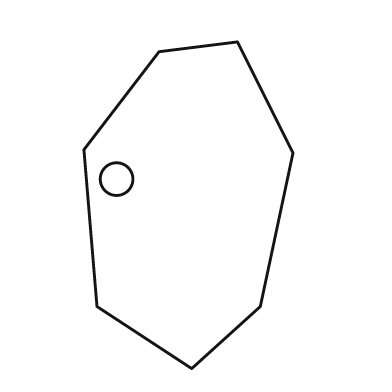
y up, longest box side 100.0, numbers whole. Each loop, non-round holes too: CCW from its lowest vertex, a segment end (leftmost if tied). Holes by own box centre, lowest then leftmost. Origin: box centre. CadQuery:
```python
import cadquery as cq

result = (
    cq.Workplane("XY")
    .moveTo(1.0, -50.0)
    .lineTo(22.0, -31.0)
    .lineTo(32.0, 16.0)
    .lineTo(15.0, 50.0)
    .lineTo(-9.0, 47.0)
    .lineTo(-32.0, 17.0)
    .lineTo(-28.0, -31.0)
    .close()
    .moveTo(-22.0, 8.0)
    .circle(5.0)
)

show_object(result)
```